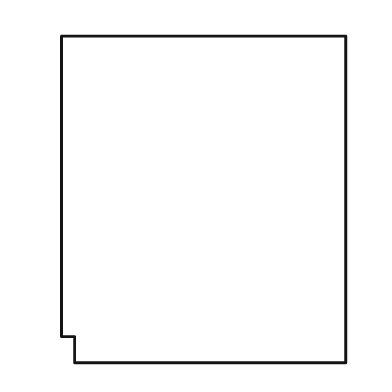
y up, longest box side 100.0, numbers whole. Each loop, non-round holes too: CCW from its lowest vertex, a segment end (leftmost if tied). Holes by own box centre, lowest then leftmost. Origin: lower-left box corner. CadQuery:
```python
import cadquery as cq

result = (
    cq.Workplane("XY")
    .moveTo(4.0, 0.0)
    .lineTo(87.0, 0.0)
    .lineTo(87.0, 100.0)
    .lineTo(0.0, 100.0)
    .lineTo(0.0, 8.0)
    .lineTo(4.0, 8.0)
    .close()
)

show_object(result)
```